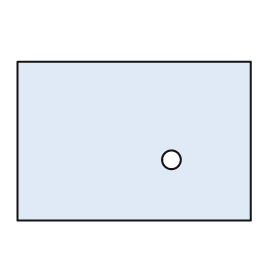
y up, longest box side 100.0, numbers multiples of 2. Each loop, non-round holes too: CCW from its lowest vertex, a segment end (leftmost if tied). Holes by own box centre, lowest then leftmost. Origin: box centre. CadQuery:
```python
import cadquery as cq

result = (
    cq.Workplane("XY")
    .moveTo(-50.0, -34.0)
    .lineTo(50.0, -34.0)
    .lineTo(50.0, 34.0)
    .lineTo(-50.0, 34.0)
    .close()
    .moveTo(16.0, -8.0)
    .circle(4.0)
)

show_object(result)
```